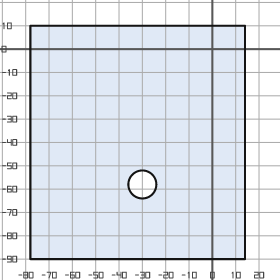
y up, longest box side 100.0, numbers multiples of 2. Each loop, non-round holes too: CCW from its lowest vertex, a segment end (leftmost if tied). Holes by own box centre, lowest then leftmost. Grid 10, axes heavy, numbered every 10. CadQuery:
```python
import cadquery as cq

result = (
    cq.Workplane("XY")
    .moveTo(-78.0, -90.0)
    .lineTo(14.0, -90.0)
    .lineTo(14.0, 10.0)
    .lineTo(-78.0, 10.0)
    .close()
    .moveTo(-30.0, -58.0)
    .circle(6.0)
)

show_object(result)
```